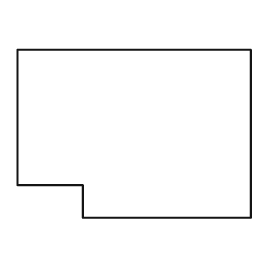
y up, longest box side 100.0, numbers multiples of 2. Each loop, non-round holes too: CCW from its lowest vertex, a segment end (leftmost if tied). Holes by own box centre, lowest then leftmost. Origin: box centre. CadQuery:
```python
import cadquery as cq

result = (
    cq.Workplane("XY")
    .moveTo(-22.0, -36.0)
    .lineTo(50.0, -36.0)
    .lineTo(50.0, 36.0)
    .lineTo(-50.0, 36.0)
    .lineTo(-50.0, -22.0)
    .lineTo(-22.0, -22.0)
    .close()
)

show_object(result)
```